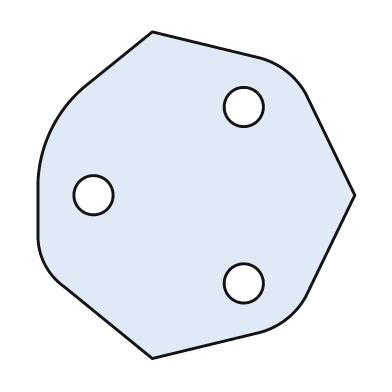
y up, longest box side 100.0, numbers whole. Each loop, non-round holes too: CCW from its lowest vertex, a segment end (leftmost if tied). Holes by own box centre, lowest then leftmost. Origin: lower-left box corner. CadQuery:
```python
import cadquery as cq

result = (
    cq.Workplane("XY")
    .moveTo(35.0, 0.0)
    .lineTo(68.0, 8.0)
    .threePointArc((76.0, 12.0), (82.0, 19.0))
    .lineTo(97.0, 50.0)
    .lineTo(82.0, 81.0)
    .threePointArc((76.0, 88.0), (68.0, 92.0))
    .lineTo(35.0, 100.0)
    .lineTo(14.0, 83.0)
    .threePointArc((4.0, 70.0), (0.0, 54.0))
    .lineTo(0.0, 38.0)
    .threePointArc((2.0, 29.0), (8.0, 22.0))
    .close()
    .moveTo(63.0, 23.0)
    .circle(6.0)
    .moveTo(17.0, 50.0)
    .circle(6.0)
    .moveTo(63.0, 77.0)
    .circle(6.0)
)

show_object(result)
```